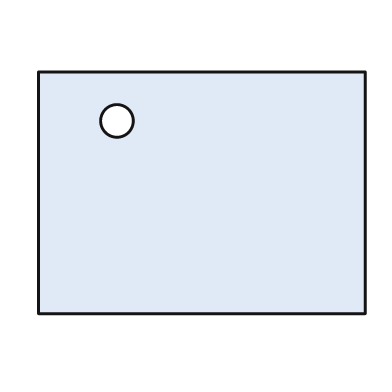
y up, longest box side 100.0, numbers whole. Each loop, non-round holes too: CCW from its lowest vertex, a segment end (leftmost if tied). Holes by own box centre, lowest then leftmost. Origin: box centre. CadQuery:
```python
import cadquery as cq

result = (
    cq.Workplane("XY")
    .moveTo(-50.0, -37.0)
    .lineTo(50.0, -37.0)
    .lineTo(50.0, 37.0)
    .lineTo(-50.0, 37.0)
    .close()
    .moveTo(-26.0, 22.0)
    .circle(5.0)
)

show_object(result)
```